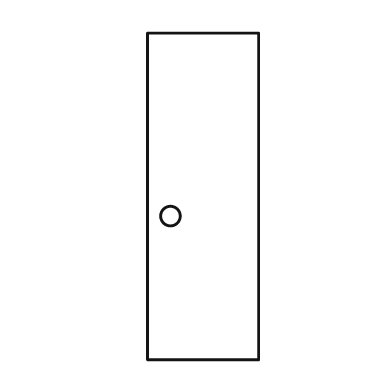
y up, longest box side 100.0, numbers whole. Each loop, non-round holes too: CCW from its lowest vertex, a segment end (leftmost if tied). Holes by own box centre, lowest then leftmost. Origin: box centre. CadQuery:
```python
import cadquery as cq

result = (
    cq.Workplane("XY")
    .moveTo(-17.0, -50.0)
    .lineTo(17.0, -50.0)
    .lineTo(17.0, 50.0)
    .lineTo(-17.0, 50.0)
    .close()
    .moveTo(-10.0, -6.0)
    .circle(3.0)
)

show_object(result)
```